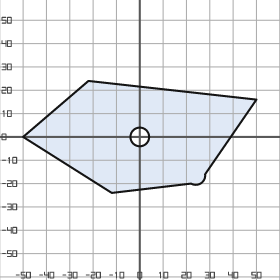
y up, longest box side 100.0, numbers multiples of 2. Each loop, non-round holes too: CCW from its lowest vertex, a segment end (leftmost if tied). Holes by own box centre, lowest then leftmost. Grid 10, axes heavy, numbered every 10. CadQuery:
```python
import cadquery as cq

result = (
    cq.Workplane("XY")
    .moveTo(-12.0, -24.0)
    .lineTo(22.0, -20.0)
    .threePointArc((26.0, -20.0), (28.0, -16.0))
    .lineTo(50.0, 16.0)
    .lineTo(-22.0, 24.0)
    .lineTo(-50.0, 0.0)
    .close()
    .moveTo(0.0, 0.0)
    .circle(4.0)
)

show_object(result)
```